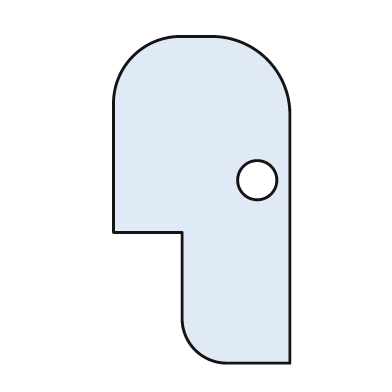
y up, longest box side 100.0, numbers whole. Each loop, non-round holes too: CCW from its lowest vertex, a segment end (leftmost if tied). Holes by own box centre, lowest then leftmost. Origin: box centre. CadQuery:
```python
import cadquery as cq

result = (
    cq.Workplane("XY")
    .moveTo(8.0, -50.0)
    .lineTo(27.0, -50.0)
    .lineTo(27.0, 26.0)
    .threePointArc((20.0, 43.0), (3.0, 50.0))
    .lineTo(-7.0, 50.0)
    .threePointArc((-21.0, 44.0), (-27.0, 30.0))
    .lineTo(-27.0, -10.0)
    .lineTo(-6.0, -10.0)
    .lineTo(-6.0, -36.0)
    .threePointArc((-2.0, -46.0), (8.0, -50.0))
    .close()
    .moveTo(17.0, 6.0)
    .circle(6.0)
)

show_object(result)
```